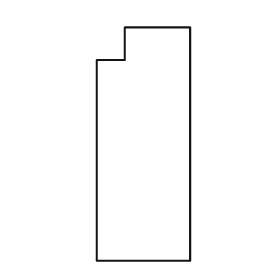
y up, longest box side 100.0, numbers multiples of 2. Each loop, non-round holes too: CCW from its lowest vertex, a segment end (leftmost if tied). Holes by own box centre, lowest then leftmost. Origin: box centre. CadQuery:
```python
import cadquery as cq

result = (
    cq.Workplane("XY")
    .moveTo(-20.0, -50.0)
    .lineTo(20.0, -50.0)
    .lineTo(20.0, 50.0)
    .lineTo(-8.0, 50.0)
    .lineTo(-8.0, 36.0)
    .lineTo(-20.0, 36.0)
    .close()
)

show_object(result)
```